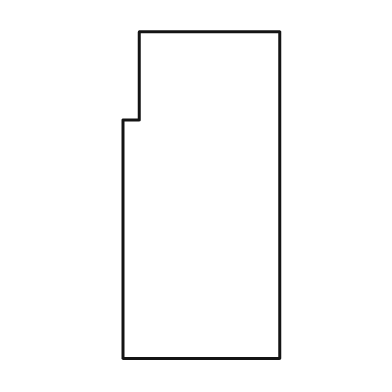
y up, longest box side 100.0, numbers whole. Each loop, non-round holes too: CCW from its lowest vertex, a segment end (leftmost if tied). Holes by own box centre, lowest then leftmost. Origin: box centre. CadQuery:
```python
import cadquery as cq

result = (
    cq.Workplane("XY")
    .moveTo(-24.0, -50.0)
    .lineTo(24.0, -50.0)
    .lineTo(24.0, 50.0)
    .lineTo(-19.0, 50.0)
    .lineTo(-19.0, 23.0)
    .lineTo(-24.0, 23.0)
    .close()
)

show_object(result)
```